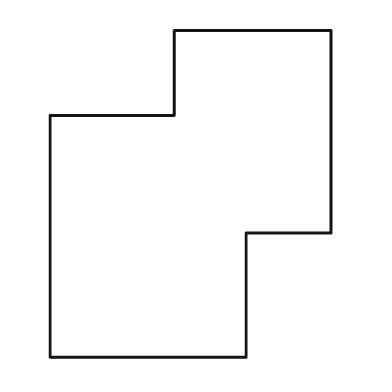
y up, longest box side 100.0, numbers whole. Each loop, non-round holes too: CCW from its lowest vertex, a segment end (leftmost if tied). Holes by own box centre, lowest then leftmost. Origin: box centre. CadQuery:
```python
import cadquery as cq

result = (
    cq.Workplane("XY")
    .moveTo(-43.0, -50.0)
    .lineTo(17.0, -50.0)
    .lineTo(17.0, -12.0)
    .lineTo(43.0, -12.0)
    .lineTo(43.0, 50.0)
    .lineTo(-5.0, 50.0)
    .lineTo(-5.0, 24.0)
    .lineTo(-43.0, 24.0)
    .close()
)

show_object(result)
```